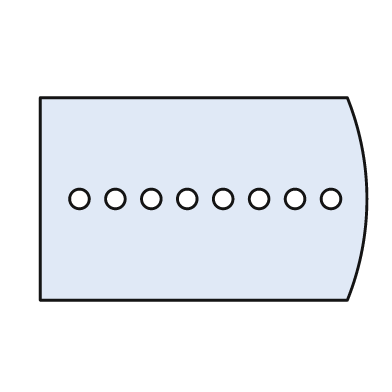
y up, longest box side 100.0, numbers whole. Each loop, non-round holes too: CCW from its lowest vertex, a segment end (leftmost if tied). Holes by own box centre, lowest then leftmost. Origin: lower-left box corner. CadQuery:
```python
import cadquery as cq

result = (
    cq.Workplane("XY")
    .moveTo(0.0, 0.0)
    .lineTo(94.0, 0.0)
    .threePointArc((100.0, 31.0), (94.0, 62.0))
    .lineTo(0.0, 62.0)
    .close()
    .moveTo(12.0, 31.0)
    .circle(3.0)
    .moveTo(23.0, 31.0)
    .circle(3.0)
    .moveTo(34.0, 31.0)
    .circle(3.0)
    .moveTo(45.0, 31.0)
    .circle(3.0)
    .moveTo(56.0, 31.0)
    .circle(3.0)
    .moveTo(67.0, 31.0)
    .circle(3.0)
    .moveTo(78.0, 31.0)
    .circle(3.0)
    .moveTo(89.0, 31.0)
    .circle(3.0)
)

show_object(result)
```